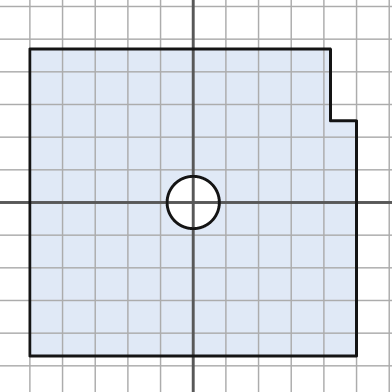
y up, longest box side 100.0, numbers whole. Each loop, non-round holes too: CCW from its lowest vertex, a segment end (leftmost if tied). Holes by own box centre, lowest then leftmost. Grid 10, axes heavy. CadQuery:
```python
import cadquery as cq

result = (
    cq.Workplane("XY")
    .moveTo(-50.0, -47.0)
    .lineTo(50.0, -47.0)
    .lineTo(50.0, 25.0)
    .lineTo(42.0, 25.0)
    .lineTo(42.0, 47.0)
    .lineTo(-50.0, 47.0)
    .close()
    .moveTo(0.0, 0.0)
    .circle(8.0)
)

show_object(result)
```